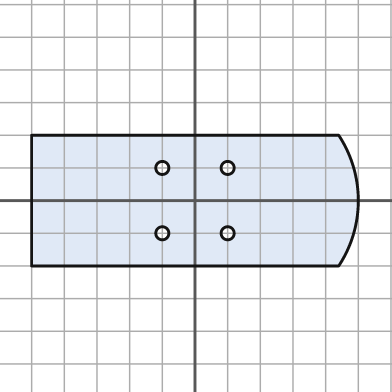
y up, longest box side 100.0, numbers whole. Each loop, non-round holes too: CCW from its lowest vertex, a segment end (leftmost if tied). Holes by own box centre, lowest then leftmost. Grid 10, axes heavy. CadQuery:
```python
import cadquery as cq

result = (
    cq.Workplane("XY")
    .moveTo(-50.0, -20.0)
    .lineTo(44.0, -20.0)
    .threePointArc((50.0, 0.0), (44.0, 20.0))
    .lineTo(-50.0, 20.0)
    .close()
    .moveTo(-10.0, -10.0)
    .circle(2.0)
    .moveTo(10.0, -10.0)
    .circle(2.0)
    .moveTo(-10.0, 10.0)
    .circle(2.0)
    .moveTo(10.0, 10.0)
    .circle(2.0)
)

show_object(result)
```